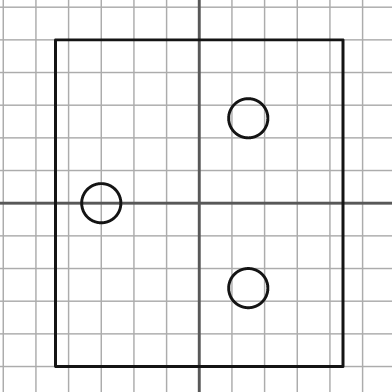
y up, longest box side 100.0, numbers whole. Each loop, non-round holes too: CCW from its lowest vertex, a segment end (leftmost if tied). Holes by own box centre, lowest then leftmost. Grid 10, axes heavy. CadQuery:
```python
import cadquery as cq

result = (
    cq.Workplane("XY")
    .moveTo(-44.0, -50.0)
    .lineTo(44.0, -50.0)
    .lineTo(44.0, 50.0)
    .lineTo(-44.0, 50.0)
    .close()
    .moveTo(15.0, -26.0)
    .circle(6.0)
    .moveTo(-30.0, 0.0)
    .circle(6.0)
    .moveTo(15.0, 26.0)
    .circle(6.0)
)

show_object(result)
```